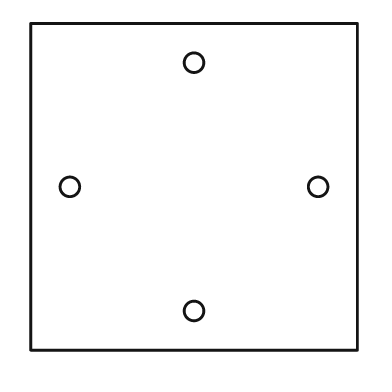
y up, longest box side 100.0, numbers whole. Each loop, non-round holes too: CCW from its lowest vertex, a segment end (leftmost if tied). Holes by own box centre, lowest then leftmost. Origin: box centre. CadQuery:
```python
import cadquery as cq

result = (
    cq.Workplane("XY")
    .moveTo(-50.0, -50.0)
    .lineTo(50.0, -50.0)
    .lineTo(50.0, 50.0)
    .lineTo(-50.0, 50.0)
    .close()
    .moveTo(0.0, -38.0)
    .circle(3.0)
    .moveTo(-38.0, 0.0)
    .circle(3.0)
    .moveTo(38.0, 0.0)
    .circle(3.0)
    .moveTo(0.0, 38.0)
    .circle(3.0)
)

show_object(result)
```